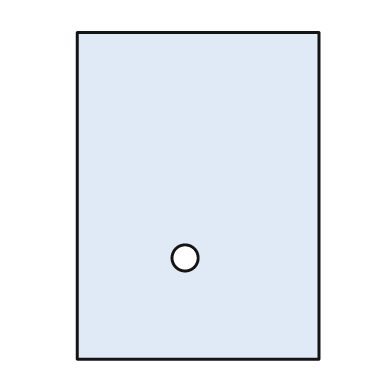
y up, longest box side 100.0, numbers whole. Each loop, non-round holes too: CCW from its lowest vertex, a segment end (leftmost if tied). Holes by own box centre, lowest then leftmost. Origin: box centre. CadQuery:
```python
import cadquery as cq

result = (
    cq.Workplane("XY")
    .moveTo(-37.0, -50.0)
    .lineTo(37.0, -50.0)
    .lineTo(37.0, 50.0)
    .lineTo(-37.0, 50.0)
    .close()
    .moveTo(-4.0, -19.0)
    .circle(4.0)
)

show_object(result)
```